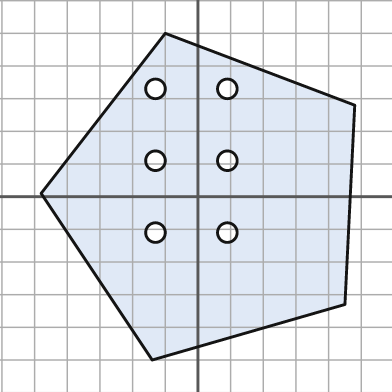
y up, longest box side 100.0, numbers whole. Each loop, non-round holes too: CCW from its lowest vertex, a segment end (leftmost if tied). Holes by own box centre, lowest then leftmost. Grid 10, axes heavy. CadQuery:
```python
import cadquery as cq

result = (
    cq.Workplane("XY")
    .moveTo(-14.0, -50.0)
    .lineTo(45.0, -33.0)
    .lineTo(48.0, 28.0)
    .lineTo(-10.0, 50.0)
    .lineTo(-48.0, 1.0)
    .close()
    .moveTo(-13.0, -11.0)
    .circle(3.0)
    .moveTo(9.0, -11.0)
    .circle(3.0)
    .moveTo(-13.0, 11.0)
    .circle(3.0)
    .moveTo(9.0, 11.0)
    .circle(3.0)
    .moveTo(-13.0, 33.0)
    .circle(3.0)
    .moveTo(9.0, 33.0)
    .circle(3.0)
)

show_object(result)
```